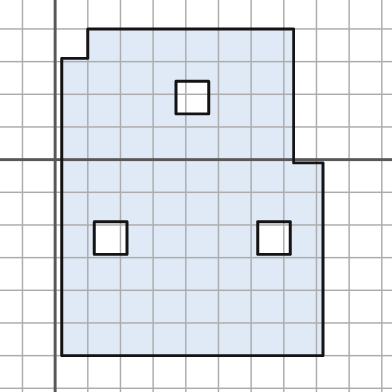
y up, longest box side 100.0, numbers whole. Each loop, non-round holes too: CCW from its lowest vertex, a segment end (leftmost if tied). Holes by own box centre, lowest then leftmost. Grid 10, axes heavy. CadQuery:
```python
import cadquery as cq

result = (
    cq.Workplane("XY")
    .moveTo(2.0, -60.0)
    .lineTo(82.0, -60.0)
    .lineTo(82.0, -1.0)
    .lineTo(73.0, -1.0)
    .lineTo(73.0, 40.0)
    .lineTo(10.0, 40.0)
    .lineTo(10.0, 31.0)
    .lineTo(2.0, 31.0)
    .close()
    .moveTo(12.0, -29.0)
    .lineTo(22.0, -29.0)
    .lineTo(22.0, -19.0)
    .lineTo(12.0, -19.0)
    .close()
    .moveTo(62.0, -29.0)
    .lineTo(72.0, -29.0)
    .lineTo(72.0, -19.0)
    .lineTo(62.0, -19.0)
    .close()
    .moveTo(37.0, 14.0)
    .lineTo(47.0, 14.0)
    .lineTo(47.0, 24.0)
    .lineTo(37.0, 24.0)
    .close()
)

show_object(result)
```